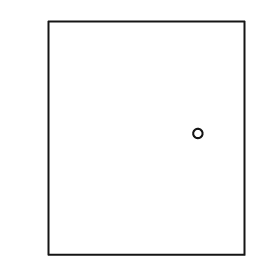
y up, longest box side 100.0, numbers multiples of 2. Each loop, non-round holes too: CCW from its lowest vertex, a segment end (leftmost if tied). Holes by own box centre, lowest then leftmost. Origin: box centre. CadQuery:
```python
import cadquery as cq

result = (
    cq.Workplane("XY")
    .moveTo(-42.0, -50.0)
    .lineTo(42.0, -50.0)
    .lineTo(42.0, 50.0)
    .lineTo(-42.0, 50.0)
    .close()
    .moveTo(22.0, 2.0)
    .circle(2.0)
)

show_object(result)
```